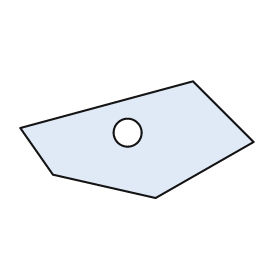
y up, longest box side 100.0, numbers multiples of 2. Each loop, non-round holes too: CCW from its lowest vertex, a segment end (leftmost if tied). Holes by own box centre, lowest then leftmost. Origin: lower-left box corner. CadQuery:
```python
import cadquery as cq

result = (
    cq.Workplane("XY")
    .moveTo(58.0, 0.0)
    .lineTo(100.0, 24.0)
    .lineTo(74.0, 50.0)
    .lineTo(0.0, 30.0)
    .lineTo(14.0, 10.0)
    .close()
    .moveTo(46.0, 28.0)
    .circle(6.0)
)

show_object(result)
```